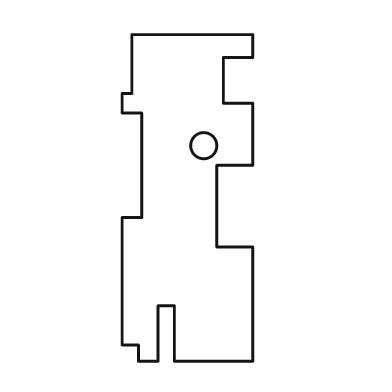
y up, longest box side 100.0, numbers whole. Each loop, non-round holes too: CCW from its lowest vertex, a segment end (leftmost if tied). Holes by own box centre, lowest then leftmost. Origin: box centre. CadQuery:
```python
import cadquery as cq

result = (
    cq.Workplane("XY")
    .moveTo(-15.0, -50.0)
    .lineTo(-9.0, -50.0)
    .lineTo(-9.0, -33.0)
    .lineTo(-4.0, -33.0)
    .lineTo(-4.0, -50.0)
    .lineTo(20.0, -50.0)
    .lineTo(20.0, -15.0)
    .lineTo(9.0, -15.0)
    .lineTo(9.0, 10.0)
    .lineTo(20.0, 10.0)
    .lineTo(20.0, 29.0)
    .lineTo(11.0, 29.0)
    .lineTo(11.0, 43.0)
    .lineTo(20.0, 43.0)
    .lineTo(20.0, 50.0)
    .lineTo(-17.0, 50.0)
    .lineTo(-17.0, 32.0)
    .lineTo(-20.0, 32.0)
    .lineTo(-20.0, 26.0)
    .lineTo(-14.0, 26.0)
    .lineTo(-14.0, -6.0)
    .lineTo(-20.0, -6.0)
    .lineTo(-20.0, -45.0)
    .lineTo(-15.0, -45.0)
    .close()
    .moveTo(5.0, 16.0)
    .circle(4.0)
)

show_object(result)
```